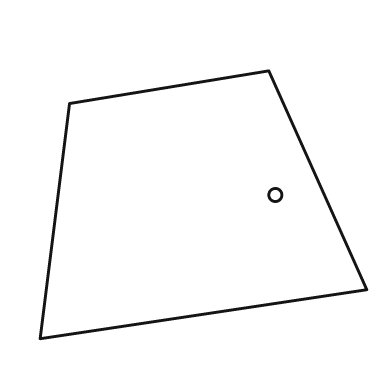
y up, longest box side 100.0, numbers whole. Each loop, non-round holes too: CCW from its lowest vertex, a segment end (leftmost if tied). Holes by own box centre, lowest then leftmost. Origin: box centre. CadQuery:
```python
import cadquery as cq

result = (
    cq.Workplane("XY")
    .moveTo(-50.0, -41.0)
    .lineTo(50.0, -26.0)
    .lineTo(20.0, 41.0)
    .lineTo(-41.0, 31.0)
    .close()
    .moveTo(22.0, 3.0)
    .circle(2.0)
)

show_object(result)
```